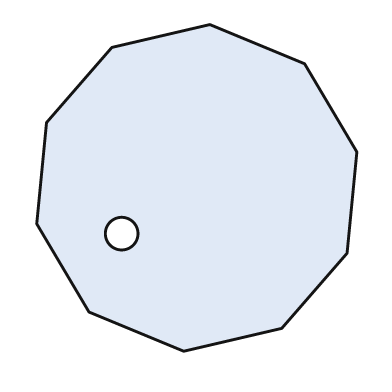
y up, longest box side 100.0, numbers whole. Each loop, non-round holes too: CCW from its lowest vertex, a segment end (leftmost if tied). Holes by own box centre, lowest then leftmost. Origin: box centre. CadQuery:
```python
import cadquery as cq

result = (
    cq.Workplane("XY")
    .moveTo(-4.0, -50.0)
    .lineTo(26.0, -43.0)
    .lineTo(46.0, -20.0)
    .lineTo(49.0, 11.0)
    .lineTo(33.0, 38.0)
    .lineTo(4.0, 50.0)
    .lineTo(-26.0, 43.0)
    .lineTo(-46.0, 20.0)
    .lineTo(-49.0, -11.0)
    .lineTo(-33.0, -38.0)
    .close()
    .moveTo(-23.0, -14.0)
    .circle(5.0)
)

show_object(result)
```